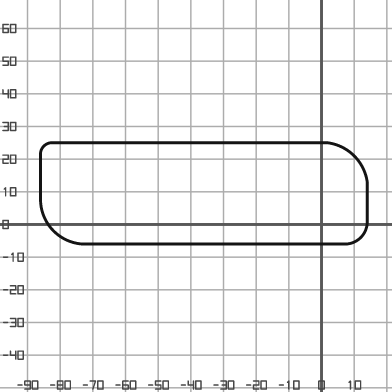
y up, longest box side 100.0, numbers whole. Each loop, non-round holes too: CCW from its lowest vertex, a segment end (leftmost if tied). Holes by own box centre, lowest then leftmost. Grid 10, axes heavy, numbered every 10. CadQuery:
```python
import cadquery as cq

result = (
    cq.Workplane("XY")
    .moveTo(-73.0, -6.0)
    .lineTo(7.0, -6.0)
    .threePointArc((12.0, -4.0), (14.0, 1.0))
    .lineTo(14.0, 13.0)
    .threePointArc((10.0, 21.0), (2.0, 25.0))
    .lineTo(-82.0, 25.0)
    .threePointArc((-85.0, 24.0), (-86.0, 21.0))
    .lineTo(-86.0, 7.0)
    .threePointArc((-82.0, -2.0), (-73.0, -6.0))
    .close()
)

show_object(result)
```